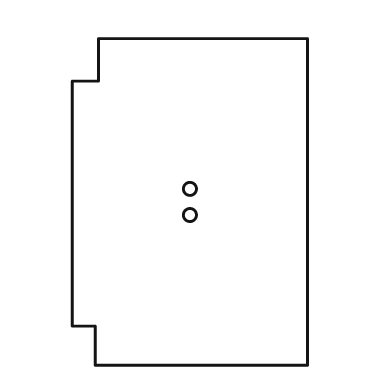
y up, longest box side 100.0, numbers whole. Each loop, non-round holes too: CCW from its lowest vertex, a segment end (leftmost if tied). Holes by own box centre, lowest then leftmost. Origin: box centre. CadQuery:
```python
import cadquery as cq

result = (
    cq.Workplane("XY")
    .moveTo(-29.0, -50.0)
    .lineTo(36.0, -50.0)
    .lineTo(36.0, 50.0)
    .lineTo(-28.0, 50.0)
    .lineTo(-28.0, 37.0)
    .lineTo(-36.0, 37.0)
    .lineTo(-36.0, -38.0)
    .lineTo(-29.0, -38.0)
    .close()
    .moveTo(0.0, -4.0)
    .circle(2.0)
    .moveTo(0.0, 4.0)
    .circle(2.0)
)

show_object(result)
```